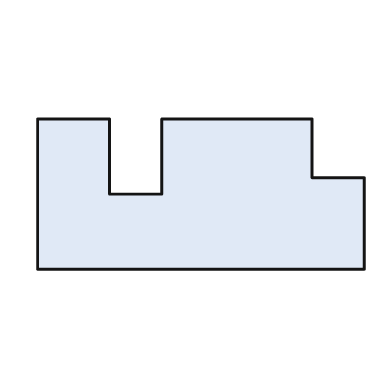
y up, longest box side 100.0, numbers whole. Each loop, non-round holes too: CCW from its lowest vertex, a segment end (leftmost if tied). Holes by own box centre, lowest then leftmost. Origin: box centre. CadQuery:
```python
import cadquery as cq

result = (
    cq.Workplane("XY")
    .moveTo(-50.0, -23.0)
    .lineTo(50.0, -23.0)
    .lineTo(50.0, 5.0)
    .lineTo(34.0, 5.0)
    .lineTo(34.0, 23.0)
    .lineTo(-12.0, 23.0)
    .lineTo(-12.0, 0.0)
    .lineTo(-28.0, 0.0)
    .lineTo(-28.0, 23.0)
    .lineTo(-50.0, 23.0)
    .close()
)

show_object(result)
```